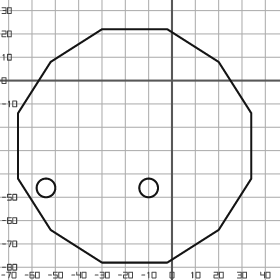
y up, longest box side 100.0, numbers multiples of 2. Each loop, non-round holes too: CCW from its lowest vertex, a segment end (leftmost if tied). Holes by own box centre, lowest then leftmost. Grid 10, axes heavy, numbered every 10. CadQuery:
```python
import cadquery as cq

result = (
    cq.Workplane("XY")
    .moveTo(-30.0, -78.0)
    .lineTo(-2.0, -78.0)
    .lineTo(20.0, -64.0)
    .lineTo(34.0, -42.0)
    .lineTo(34.0, -14.0)
    .lineTo(20.0, 8.0)
    .lineTo(-2.0, 22.0)
    .lineTo(-30.0, 22.0)
    .lineTo(-52.0, 8.0)
    .lineTo(-66.0, -14.0)
    .lineTo(-66.0, -42.0)
    .lineTo(-52.0, -64.0)
    .close()
    .moveTo(-54.0, -46.0)
    .circle(4.0)
    .moveTo(-10.0, -46.0)
    .circle(4.0)
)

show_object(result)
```